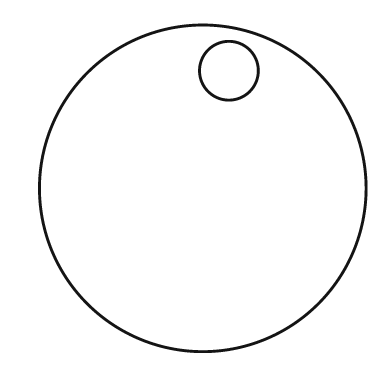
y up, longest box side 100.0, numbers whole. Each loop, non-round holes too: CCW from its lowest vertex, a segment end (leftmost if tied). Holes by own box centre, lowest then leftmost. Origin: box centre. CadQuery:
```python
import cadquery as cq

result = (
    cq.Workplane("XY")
    .moveTo(0.0, 0.0)
    .circle(50.0)
    .moveTo(8.0, 36.0)
    .circle(9.0)
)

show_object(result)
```